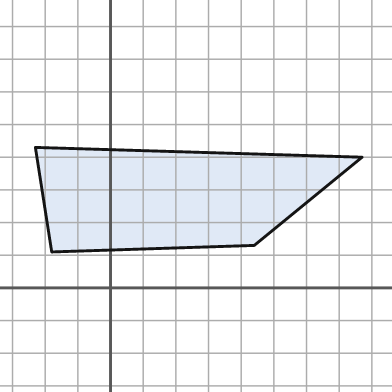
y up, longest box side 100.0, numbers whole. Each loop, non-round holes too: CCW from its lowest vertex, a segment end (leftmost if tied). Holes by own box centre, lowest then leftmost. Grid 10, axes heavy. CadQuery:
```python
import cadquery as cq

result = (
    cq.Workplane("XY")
    .moveTo(-18.0, 11.0)
    .lineTo(44.0, 13.0)
    .lineTo(77.0, 40.0)
    .lineTo(-23.0, 43.0)
    .close()
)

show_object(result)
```